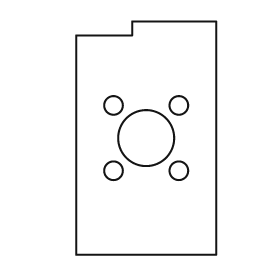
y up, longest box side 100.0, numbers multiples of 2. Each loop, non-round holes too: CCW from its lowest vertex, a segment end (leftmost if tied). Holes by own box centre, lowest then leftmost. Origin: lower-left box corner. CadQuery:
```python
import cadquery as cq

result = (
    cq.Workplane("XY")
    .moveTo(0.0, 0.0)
    .lineTo(60.0, 0.0)
    .lineTo(60.0, 100.0)
    .lineTo(24.0, 100.0)
    .lineTo(24.0, 94.0)
    .lineTo(0.0, 94.0)
    .close()
    .moveTo(16.0, 36.0)
    .circle(4.0)
    .moveTo(44.0, 36.0)
    .circle(4.0)
    .moveTo(30.0, 50.0)
    .circle(12.0)
    .moveTo(16.0, 64.0)
    .circle(4.0)
    .moveTo(44.0, 64.0)
    .circle(4.0)
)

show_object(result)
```